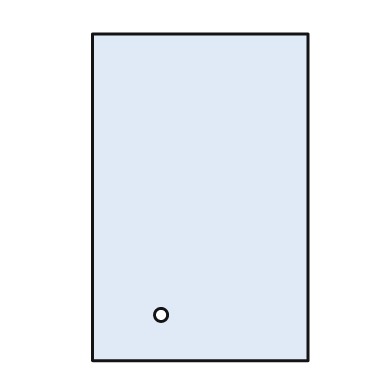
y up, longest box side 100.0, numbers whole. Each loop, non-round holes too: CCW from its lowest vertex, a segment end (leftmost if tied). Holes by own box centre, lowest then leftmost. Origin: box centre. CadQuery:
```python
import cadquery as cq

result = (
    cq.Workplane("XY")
    .moveTo(-33.0, -50.0)
    .lineTo(33.0, -50.0)
    .lineTo(33.0, 50.0)
    .lineTo(-33.0, 50.0)
    .close()
    .moveTo(-12.0, -36.0)
    .circle(2.0)
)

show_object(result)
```